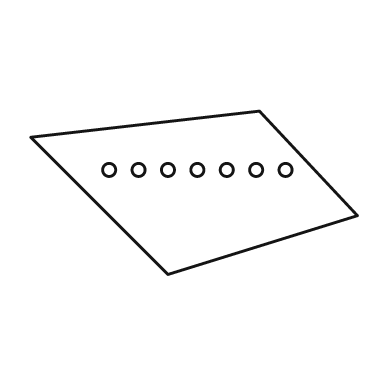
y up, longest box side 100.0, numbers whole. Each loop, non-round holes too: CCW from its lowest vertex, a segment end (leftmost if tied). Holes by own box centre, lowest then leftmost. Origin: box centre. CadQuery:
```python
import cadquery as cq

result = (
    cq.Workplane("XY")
    .moveTo(-8.0, -25.0)
    .lineTo(50.0, -7.0)
    .lineTo(20.0, 25.0)
    .lineTo(-50.0, 17.0)
    .close()
    .moveTo(-26.0, 7.0)
    .circle(2.0)
    .moveTo(-17.0, 7.0)
    .circle(2.0)
    .moveTo(-8.0, 7.0)
    .circle(2.0)
    .moveTo(1.0, 7.0)
    .circle(2.0)
    .moveTo(10.0, 7.0)
    .circle(2.0)
    .moveTo(19.0, 7.0)
    .circle(2.0)
    .moveTo(28.0, 7.0)
    .circle(2.0)
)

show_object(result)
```